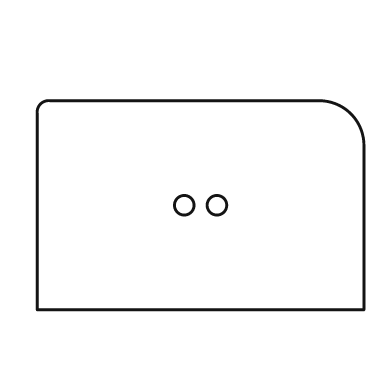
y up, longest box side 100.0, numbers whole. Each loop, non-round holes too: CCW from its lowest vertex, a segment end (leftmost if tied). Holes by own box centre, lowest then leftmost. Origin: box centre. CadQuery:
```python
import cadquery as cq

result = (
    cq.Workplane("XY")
    .moveTo(-50.0, -32.0)
    .lineTo(50.0, -32.0)
    .lineTo(50.0, 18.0)
    .threePointArc((46.0, 28.0), (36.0, 32.0))
    .lineTo(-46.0, 32.0)
    .threePointArc((-49.0, 31.0), (-50.0, 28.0))
    .close()
    .moveTo(-5.0, 0.0)
    .circle(3.0)
    .moveTo(5.0, 0.0)
    .circle(3.0)
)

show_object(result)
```